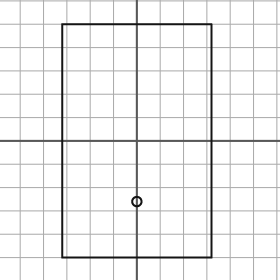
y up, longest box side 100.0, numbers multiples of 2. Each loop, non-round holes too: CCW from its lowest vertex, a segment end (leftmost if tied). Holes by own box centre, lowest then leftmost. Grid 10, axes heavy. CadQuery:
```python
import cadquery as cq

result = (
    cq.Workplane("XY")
    .moveTo(-32.0, -50.0)
    .lineTo(32.0, -50.0)
    .lineTo(32.0, 50.0)
    .lineTo(-32.0, 50.0)
    .close()
    .moveTo(0.0, -26.0)
    .circle(2.0)
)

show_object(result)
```